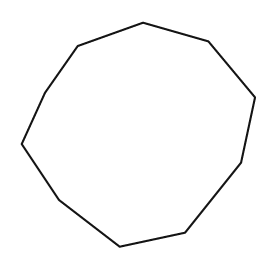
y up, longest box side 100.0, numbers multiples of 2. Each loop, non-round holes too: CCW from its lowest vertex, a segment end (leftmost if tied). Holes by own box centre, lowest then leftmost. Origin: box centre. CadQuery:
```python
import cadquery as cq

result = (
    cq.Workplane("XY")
    .moveTo(-8.0, -48.0)
    .lineTo(20.0, -42.0)
    .lineTo(44.0, -12.0)
    .lineTo(50.0, 16.0)
    .lineTo(30.0, 40.0)
    .lineTo(2.0, 48.0)
    .lineTo(-26.0, 38.0)
    .lineTo(-40.0, 18.0)
    .lineTo(-50.0, -4.0)
    .lineTo(-34.0, -28.0)
    .close()
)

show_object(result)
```